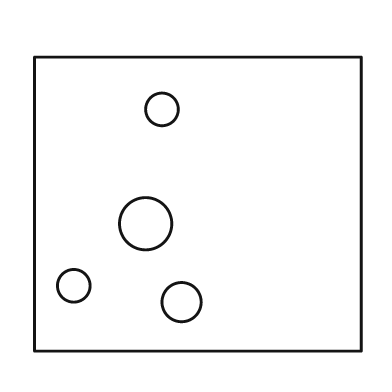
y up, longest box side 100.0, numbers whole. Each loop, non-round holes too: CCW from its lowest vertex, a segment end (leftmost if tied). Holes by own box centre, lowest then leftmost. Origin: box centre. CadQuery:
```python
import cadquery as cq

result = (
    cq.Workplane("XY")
    .moveTo(-50.0, -45.0)
    .lineTo(50.0, -45.0)
    .lineTo(50.0, 45.0)
    .lineTo(-50.0, 45.0)
    .close()
    .moveTo(-5.0, -30.0)
    .circle(6.0)
    .moveTo(-38.0, -25.0)
    .circle(5.0)
    .moveTo(-16.0, -6.0)
    .circle(8.0)
    .moveTo(-11.0, 29.0)
    .circle(5.0)
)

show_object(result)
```